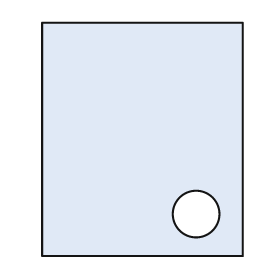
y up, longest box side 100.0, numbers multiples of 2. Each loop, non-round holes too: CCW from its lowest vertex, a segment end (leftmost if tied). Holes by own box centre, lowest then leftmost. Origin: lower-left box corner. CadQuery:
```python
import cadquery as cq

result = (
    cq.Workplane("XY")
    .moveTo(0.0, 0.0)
    .lineTo(86.0, 0.0)
    .lineTo(86.0, 100.0)
    .lineTo(0.0, 100.0)
    .close()
    .moveTo(66.0, 18.0)
    .circle(10.0)
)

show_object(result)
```